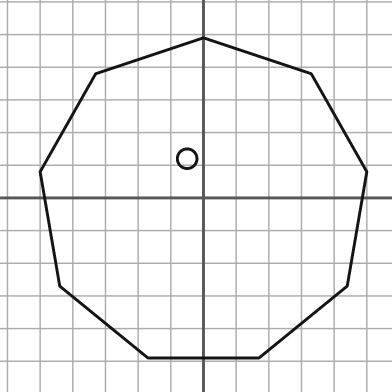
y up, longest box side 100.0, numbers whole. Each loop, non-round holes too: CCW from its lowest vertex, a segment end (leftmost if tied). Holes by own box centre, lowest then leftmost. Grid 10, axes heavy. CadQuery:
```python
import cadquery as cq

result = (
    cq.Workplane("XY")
    .moveTo(-17.0, -49.0)
    .lineTo(17.0, -49.0)
    .lineTo(44.0, -27.0)
    .lineTo(50.0, 8.0)
    .lineTo(33.0, 38.0)
    .lineTo(0.0, 49.0)
    .lineTo(-33.0, 38.0)
    .lineTo(-50.0, 8.0)
    .lineTo(-44.0, -27.0)
    .close()
    .moveTo(-5.0, 12.0)
    .circle(3.0)
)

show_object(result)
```